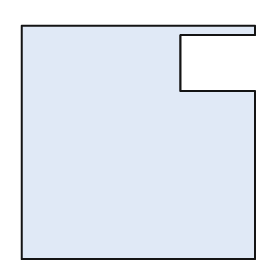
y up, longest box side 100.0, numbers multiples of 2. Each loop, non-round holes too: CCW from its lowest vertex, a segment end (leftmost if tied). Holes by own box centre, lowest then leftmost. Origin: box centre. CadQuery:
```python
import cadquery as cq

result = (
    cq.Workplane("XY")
    .moveTo(-50.0, -50.0)
    .lineTo(50.0, -50.0)
    .lineTo(50.0, 22.0)
    .lineTo(18.0, 22.0)
    .lineTo(18.0, 46.0)
    .lineTo(50.0, 46.0)
    .lineTo(50.0, 50.0)
    .lineTo(-50.0, 50.0)
    .close()
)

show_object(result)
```